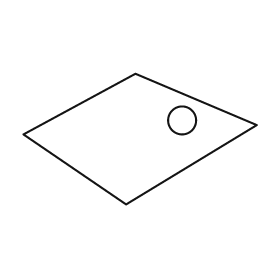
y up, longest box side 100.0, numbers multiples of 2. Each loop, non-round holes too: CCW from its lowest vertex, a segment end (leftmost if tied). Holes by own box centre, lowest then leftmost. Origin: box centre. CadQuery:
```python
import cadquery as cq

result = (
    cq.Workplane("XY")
    .moveTo(-6.0, -28.0)
    .lineTo(50.0, 6.0)
    .lineTo(-2.0, 28.0)
    .lineTo(-50.0, 2.0)
    .close()
    .moveTo(18.0, 8.0)
    .circle(6.0)
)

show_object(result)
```